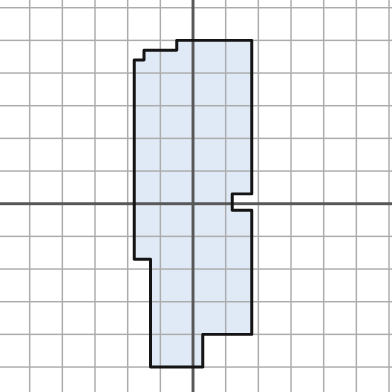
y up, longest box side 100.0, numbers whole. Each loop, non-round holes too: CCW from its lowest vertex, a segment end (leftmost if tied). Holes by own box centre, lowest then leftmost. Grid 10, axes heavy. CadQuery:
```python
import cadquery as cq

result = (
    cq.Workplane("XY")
    .moveTo(-13.0, -50.0)
    .lineTo(3.0, -50.0)
    .lineTo(3.0, -40.0)
    .lineTo(18.0, -40.0)
    .lineTo(18.0, -2.0)
    .lineTo(12.0, -2.0)
    .lineTo(12.0, 3.0)
    .lineTo(18.0, 3.0)
    .lineTo(18.0, 50.0)
    .lineTo(-5.0, 50.0)
    .lineTo(-5.0, 47.0)
    .lineTo(-15.0, 47.0)
    .lineTo(-15.0, 44.0)
    .lineTo(-18.0, 44.0)
    .lineTo(-18.0, -17.0)
    .lineTo(-13.0, -17.0)
    .close()
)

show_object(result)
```